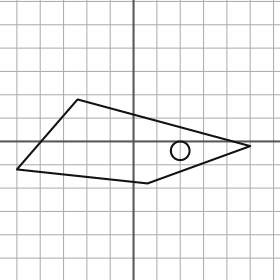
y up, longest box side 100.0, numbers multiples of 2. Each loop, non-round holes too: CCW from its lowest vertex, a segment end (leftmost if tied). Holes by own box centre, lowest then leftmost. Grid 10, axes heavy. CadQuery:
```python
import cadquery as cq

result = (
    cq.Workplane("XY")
    .moveTo(6.0, -18.0)
    .lineTo(50.0, -2.0)
    .lineTo(-24.0, 18.0)
    .lineTo(-50.0, -12.0)
    .close()
    .moveTo(20.0, -4.0)
    .circle(4.0)
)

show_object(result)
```